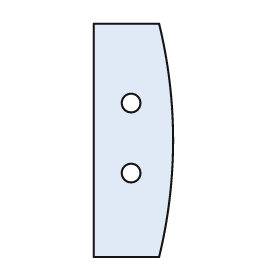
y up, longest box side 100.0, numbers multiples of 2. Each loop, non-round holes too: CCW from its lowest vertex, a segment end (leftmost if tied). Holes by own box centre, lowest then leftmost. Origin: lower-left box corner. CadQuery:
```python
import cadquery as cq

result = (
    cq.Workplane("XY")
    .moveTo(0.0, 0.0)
    .lineTo(28.0, 0.0)
    .threePointArc((34.0, 50.0), (28.0, 100.0))
    .lineTo(0.0, 100.0)
    .close()
    .moveTo(16.0, 36.0)
    .circle(4.0)
    .moveTo(16.0, 66.0)
    .circle(4.0)
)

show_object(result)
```